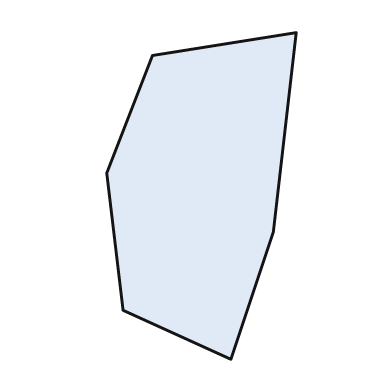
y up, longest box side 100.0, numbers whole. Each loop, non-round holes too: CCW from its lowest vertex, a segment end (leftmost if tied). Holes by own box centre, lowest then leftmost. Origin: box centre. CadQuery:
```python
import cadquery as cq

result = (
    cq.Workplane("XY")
    .moveTo(9.0, -50.0)
    .lineTo(22.0, -11.0)
    .lineTo(29.0, 50.0)
    .lineTo(-15.0, 43.0)
    .lineTo(-29.0, 7.0)
    .lineTo(-24.0, -35.0)
    .close()
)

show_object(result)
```